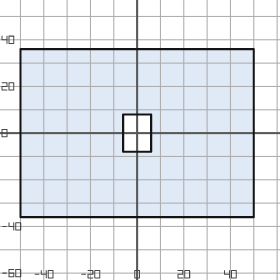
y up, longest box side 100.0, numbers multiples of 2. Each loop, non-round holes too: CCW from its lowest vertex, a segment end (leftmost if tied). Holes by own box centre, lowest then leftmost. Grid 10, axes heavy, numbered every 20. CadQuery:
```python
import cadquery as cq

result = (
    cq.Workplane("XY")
    .moveTo(-50.0, -36.0)
    .lineTo(50.0, -36.0)
    .lineTo(50.0, 36.0)
    .lineTo(-50.0, 36.0)
    .close()
    .moveTo(-6.0, -8.0)
    .lineTo(6.0, -8.0)
    .lineTo(6.0, 8.0)
    .lineTo(-6.0, 8.0)
    .close()
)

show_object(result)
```